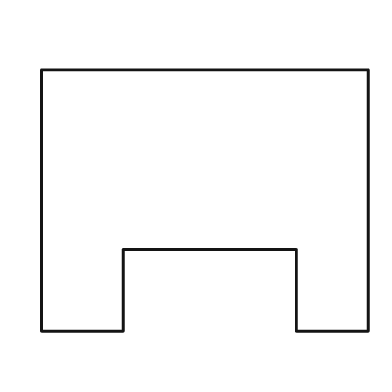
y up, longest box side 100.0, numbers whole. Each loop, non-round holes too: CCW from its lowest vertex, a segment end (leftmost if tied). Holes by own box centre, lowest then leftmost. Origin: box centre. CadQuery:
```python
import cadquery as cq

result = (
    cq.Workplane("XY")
    .moveTo(-50.0, -40.0)
    .lineTo(-25.0, -40.0)
    .lineTo(-25.0, -15.0)
    .lineTo(28.0, -15.0)
    .lineTo(28.0, -40.0)
    .lineTo(50.0, -40.0)
    .lineTo(50.0, 40.0)
    .lineTo(-50.0, 40.0)
    .close()
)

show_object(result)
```